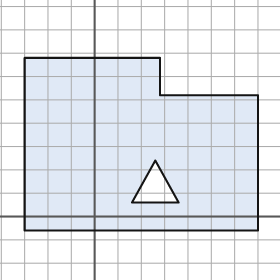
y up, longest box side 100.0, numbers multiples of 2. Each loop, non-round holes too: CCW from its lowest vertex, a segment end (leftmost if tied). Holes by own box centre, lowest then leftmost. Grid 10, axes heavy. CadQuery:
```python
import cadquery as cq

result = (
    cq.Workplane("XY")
    .moveTo(-30.0, -6.0)
    .lineTo(70.0, -6.0)
    .lineTo(70.0, 52.0)
    .lineTo(28.0, 52.0)
    .lineTo(28.0, 68.0)
    .lineTo(-30.0, 68.0)
    .close()
    .moveTo(16.0, 6.0)
    .lineTo(36.0, 6.0)
    .lineTo(26.0, 24.0)
    .close()
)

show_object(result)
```